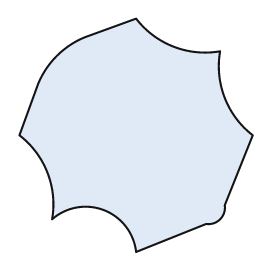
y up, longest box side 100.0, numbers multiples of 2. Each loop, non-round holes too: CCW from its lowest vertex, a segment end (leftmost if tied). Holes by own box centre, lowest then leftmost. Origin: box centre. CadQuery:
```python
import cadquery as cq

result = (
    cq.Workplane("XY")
    .moveTo(0.0, -50.0)
    .lineTo(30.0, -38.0)
    .threePointArc((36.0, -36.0), (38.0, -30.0))
    .lineTo(50.0, 0.0)
    .threePointArc((38.0, 16.0), (36.0, 36.0))
    .threePointArc((16.0, 38.0), (0.0, 50.0))
    .lineTo(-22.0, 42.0)
    .threePointArc((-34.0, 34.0), (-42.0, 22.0))
    .lineTo(-50.0, 0.0)
    .threePointArc((-38.0, -16.0), (-36.0, -36.0))
    .threePointArc((-14.0, -32.0), (0.0, -50.0))
    .close()
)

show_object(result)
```